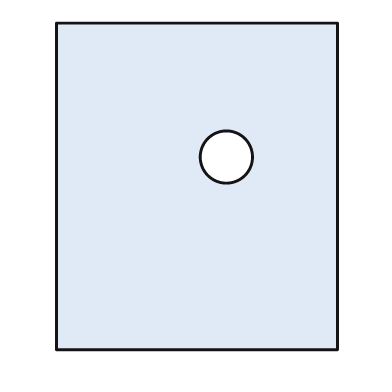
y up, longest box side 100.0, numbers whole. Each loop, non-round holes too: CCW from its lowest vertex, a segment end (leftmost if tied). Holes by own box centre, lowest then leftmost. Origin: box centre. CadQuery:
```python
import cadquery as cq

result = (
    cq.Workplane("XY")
    .moveTo(-43.0, -50.0)
    .lineTo(43.0, -50.0)
    .lineTo(43.0, 50.0)
    .lineTo(-43.0, 50.0)
    .close()
    .moveTo(9.0, 9.0)
    .circle(8.0)
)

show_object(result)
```